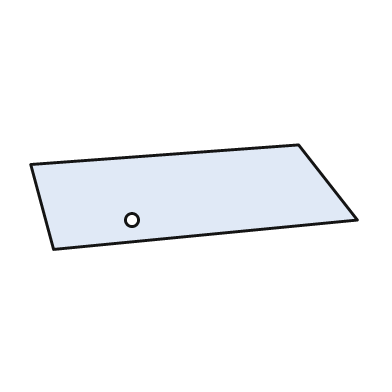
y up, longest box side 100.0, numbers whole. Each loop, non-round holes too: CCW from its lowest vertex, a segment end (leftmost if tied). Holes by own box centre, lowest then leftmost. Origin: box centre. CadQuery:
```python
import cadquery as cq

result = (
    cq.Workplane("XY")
    .moveTo(-43.0, -16.0)
    .lineTo(50.0, -7.0)
    .lineTo(32.0, 16.0)
    .lineTo(-50.0, 10.0)
    .close()
    .moveTo(-19.0, -7.0)
    .circle(2.0)
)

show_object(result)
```